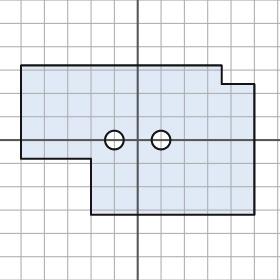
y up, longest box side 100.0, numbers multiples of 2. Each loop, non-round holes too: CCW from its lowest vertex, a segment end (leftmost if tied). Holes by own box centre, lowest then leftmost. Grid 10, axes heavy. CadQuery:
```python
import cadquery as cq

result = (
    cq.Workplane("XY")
    .moveTo(-20.0, -32.0)
    .lineTo(50.0, -32.0)
    .lineTo(50.0, 24.0)
    .lineTo(36.0, 24.0)
    .lineTo(36.0, 32.0)
    .lineTo(-50.0, 32.0)
    .lineTo(-50.0, -8.0)
    .lineTo(-20.0, -8.0)
    .close()
    .moveTo(-10.0, 0.0)
    .circle(4.0)
    .moveTo(10.0, 0.0)
    .circle(4.0)
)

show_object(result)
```